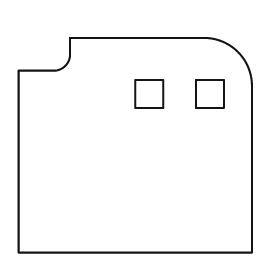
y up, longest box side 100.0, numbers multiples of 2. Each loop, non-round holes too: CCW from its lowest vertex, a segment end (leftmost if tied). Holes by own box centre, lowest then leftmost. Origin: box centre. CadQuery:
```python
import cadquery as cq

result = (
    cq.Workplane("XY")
    .moveTo(-50.0, -46.0)
    .lineTo(50.0, -46.0)
    .lineTo(50.0, 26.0)
    .threePointArc((44.0, 40.0), (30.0, 46.0))
    .lineTo(-28.0, 46.0)
    .lineTo(-28.0, 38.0)
    .threePointArc((-30.0, 34.0), (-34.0, 32.0))
    .lineTo(-50.0, 32.0)
    .close()
    .moveTo(0.0, 16.0)
    .lineTo(12.0, 16.0)
    .lineTo(12.0, 28.0)
    .lineTo(0.0, 28.0)
    .close()
    .moveTo(26.0, 16.0)
    .lineTo(38.0, 16.0)
    .lineTo(38.0, 28.0)
    .lineTo(26.0, 28.0)
    .close()
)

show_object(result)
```